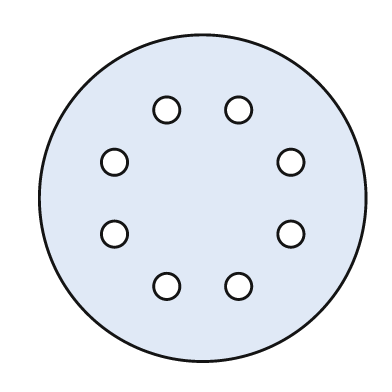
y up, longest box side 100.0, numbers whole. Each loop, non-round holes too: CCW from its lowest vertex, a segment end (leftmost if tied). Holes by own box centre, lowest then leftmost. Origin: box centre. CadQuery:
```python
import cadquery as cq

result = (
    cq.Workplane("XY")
    .moveTo(0.0, 0.0)
    .circle(50.0)
    .moveTo(-11.0, -27.0)
    .circle(4.0)
    .moveTo(11.0, -27.0)
    .circle(4.0)
    .moveTo(-27.0, -11.0)
    .circle(4.0)
    .moveTo(27.0, -11.0)
    .circle(4.0)
    .moveTo(-27.0, 11.0)
    .circle(4.0)
    .moveTo(27.0, 11.0)
    .circle(4.0)
    .moveTo(-11.0, 27.0)
    .circle(4.0)
    .moveTo(11.0, 27.0)
    .circle(4.0)
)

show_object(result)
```